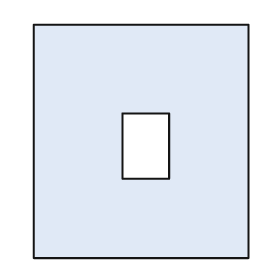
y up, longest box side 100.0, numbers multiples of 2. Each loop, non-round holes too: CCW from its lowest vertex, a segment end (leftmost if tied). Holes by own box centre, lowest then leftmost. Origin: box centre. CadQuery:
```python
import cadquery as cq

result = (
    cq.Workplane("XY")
    .moveTo(-46.0, -50.0)
    .lineTo(46.0, -50.0)
    .lineTo(46.0, 50.0)
    .lineTo(-46.0, 50.0)
    .close()
    .moveTo(-8.0, -16.0)
    .lineTo(12.0, -16.0)
    .lineTo(12.0, 12.0)
    .lineTo(-8.0, 12.0)
    .close()
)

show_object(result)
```